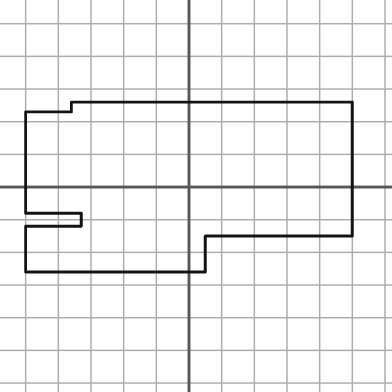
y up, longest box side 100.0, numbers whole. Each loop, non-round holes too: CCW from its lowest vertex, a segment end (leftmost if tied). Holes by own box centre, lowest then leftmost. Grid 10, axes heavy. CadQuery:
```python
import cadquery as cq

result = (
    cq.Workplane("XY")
    .moveTo(-50.0, -26.0)
    .lineTo(5.0, -26.0)
    .lineTo(5.0, -15.0)
    .lineTo(50.0, -15.0)
    .lineTo(50.0, 26.0)
    .lineTo(-36.0, 26.0)
    .lineTo(-36.0, 23.0)
    .lineTo(-50.0, 23.0)
    .lineTo(-50.0, -8.0)
    .lineTo(-33.0, -8.0)
    .lineTo(-33.0, -12.0)
    .lineTo(-50.0, -12.0)
    .close()
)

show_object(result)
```